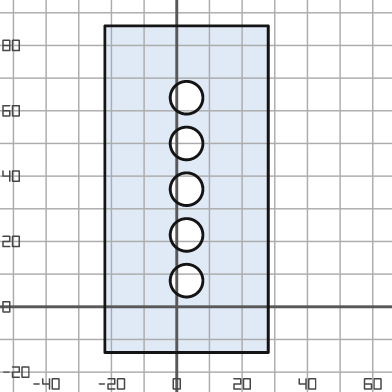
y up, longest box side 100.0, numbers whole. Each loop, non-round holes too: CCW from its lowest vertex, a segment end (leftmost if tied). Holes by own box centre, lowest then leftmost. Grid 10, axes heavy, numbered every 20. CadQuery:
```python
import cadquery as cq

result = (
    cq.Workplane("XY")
    .moveTo(-22.0, -14.0)
    .lineTo(28.0, -14.0)
    .lineTo(28.0, 86.0)
    .lineTo(-22.0, 86.0)
    .close()
    .moveTo(3.0, 8.0)
    .circle(5.0)
    .moveTo(3.0, 22.0)
    .circle(5.0)
    .moveTo(3.0, 36.0)
    .circle(5.0)
    .moveTo(3.0, 50.0)
    .circle(5.0)
    .moveTo(3.0, 64.0)
    .circle(5.0)
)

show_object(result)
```